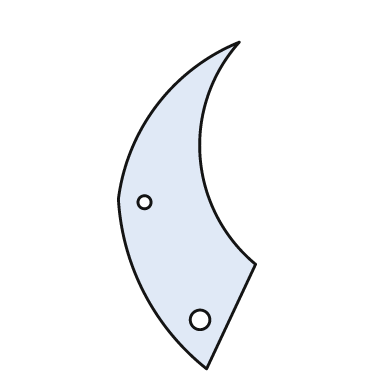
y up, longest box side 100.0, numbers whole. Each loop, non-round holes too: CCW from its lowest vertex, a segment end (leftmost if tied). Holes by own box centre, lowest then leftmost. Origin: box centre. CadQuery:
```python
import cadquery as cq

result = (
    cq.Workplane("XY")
    .moveTo(6.0, -50.0)
    .lineTo(21.0, -18.0)
    .threePointArc((4.0, 15.0), (16.0, 50.0))
    .threePointArc((-9.0, 31.0), (-21.0, 2.0))
    .threePointArc((-13.0, -27.0), (6.0, -50.0))
    .close()
    .moveTo(4.0, -35.0)
    .circle(3.0)
    .moveTo(-13.0, 1.0)
    .circle(2.0)
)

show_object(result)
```